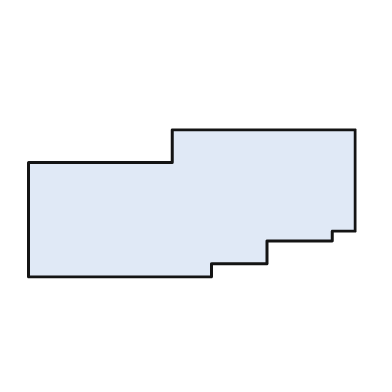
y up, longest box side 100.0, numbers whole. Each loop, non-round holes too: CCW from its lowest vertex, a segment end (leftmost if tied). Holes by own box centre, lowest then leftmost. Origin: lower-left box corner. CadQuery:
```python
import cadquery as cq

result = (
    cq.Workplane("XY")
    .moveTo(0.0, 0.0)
    .lineTo(56.0, 0.0)
    .lineTo(56.0, 4.0)
    .lineTo(73.0, 4.0)
    .lineTo(73.0, 11.0)
    .lineTo(93.0, 11.0)
    .lineTo(93.0, 14.0)
    .lineTo(100.0, 14.0)
    .lineTo(100.0, 45.0)
    .lineTo(44.0, 45.0)
    .lineTo(44.0, 35.0)
    .lineTo(0.0, 35.0)
    .close()
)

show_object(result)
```